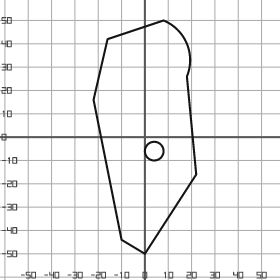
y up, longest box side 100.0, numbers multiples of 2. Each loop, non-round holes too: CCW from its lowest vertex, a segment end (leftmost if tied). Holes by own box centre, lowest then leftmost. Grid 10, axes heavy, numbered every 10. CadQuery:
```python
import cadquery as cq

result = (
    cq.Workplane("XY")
    .moveTo(0.0, -50.0)
    .lineTo(22.0, -16.0)
    .lineTo(18.0, 26.0)
    .threePointArc((18.0, 40.0), (8.0, 50.0))
    .lineTo(-16.0, 42.0)
    .lineTo(-22.0, 16.0)
    .lineTo(-10.0, -44.0)
    .close()
    .moveTo(4.0, -6.0)
    .circle(4.0)
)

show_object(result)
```